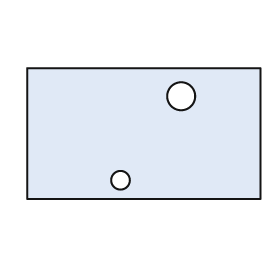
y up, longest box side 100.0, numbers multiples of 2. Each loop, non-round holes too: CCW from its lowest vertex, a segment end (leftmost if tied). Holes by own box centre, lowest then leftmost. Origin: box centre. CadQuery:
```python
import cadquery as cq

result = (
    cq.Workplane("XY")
    .moveTo(-50.0, -28.0)
    .lineTo(50.0, -28.0)
    .lineTo(50.0, 28.0)
    .lineTo(-50.0, 28.0)
    .close()
    .moveTo(-10.0, -20.0)
    .circle(4.0)
    .moveTo(16.0, 16.0)
    .circle(6.0)
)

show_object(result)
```